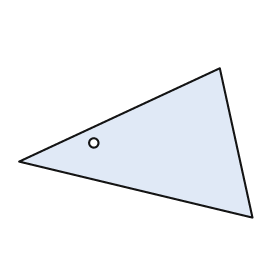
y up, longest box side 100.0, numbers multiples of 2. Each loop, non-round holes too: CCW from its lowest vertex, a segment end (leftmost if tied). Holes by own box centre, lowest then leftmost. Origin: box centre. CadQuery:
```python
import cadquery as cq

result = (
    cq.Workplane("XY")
    .moveTo(50.0, -32.0)
    .lineTo(36.0, 32.0)
    .lineTo(-50.0, -8.0)
    .close()
    .moveTo(-18.0, 0.0)
    .circle(2.0)
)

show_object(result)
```